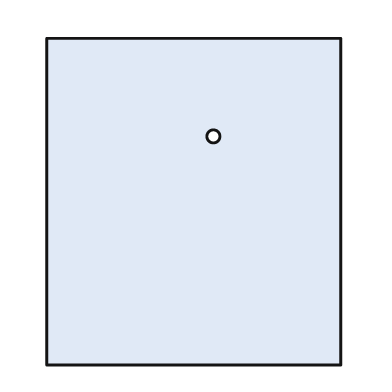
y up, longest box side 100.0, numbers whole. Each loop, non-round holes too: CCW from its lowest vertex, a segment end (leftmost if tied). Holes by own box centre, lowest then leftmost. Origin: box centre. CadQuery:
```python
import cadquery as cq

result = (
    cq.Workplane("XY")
    .moveTo(-45.0, -50.0)
    .lineTo(45.0, -50.0)
    .lineTo(45.0, 50.0)
    .lineTo(-45.0, 50.0)
    .close()
    .moveTo(6.0, 20.0)
    .circle(2.0)
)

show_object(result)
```